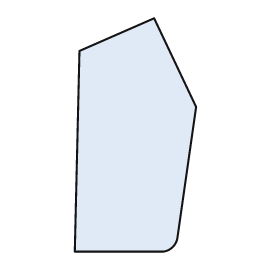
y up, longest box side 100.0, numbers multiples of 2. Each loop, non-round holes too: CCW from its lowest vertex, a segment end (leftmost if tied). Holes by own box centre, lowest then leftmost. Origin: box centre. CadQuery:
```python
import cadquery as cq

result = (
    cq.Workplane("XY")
    .moveTo(-26.0, -50.0)
    .lineTo(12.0, -50.0)
    .threePointArc((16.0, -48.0), (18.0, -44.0))
    .lineTo(26.0, 12.0)
    .lineTo(8.0, 50.0)
    .lineTo(-24.0, 36.0)
    .close()
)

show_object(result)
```